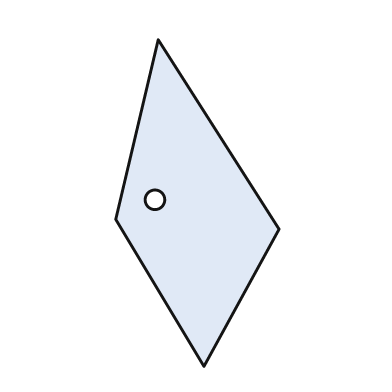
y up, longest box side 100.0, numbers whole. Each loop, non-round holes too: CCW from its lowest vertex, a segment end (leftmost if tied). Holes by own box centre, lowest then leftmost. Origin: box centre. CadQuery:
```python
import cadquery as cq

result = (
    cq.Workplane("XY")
    .moveTo(2.0, -50.0)
    .lineTo(25.0, -8.0)
    .lineTo(-12.0, 50.0)
    .lineTo(-25.0, -5.0)
    .close()
    .moveTo(-13.0, 1.0)
    .circle(3.0)
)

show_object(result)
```